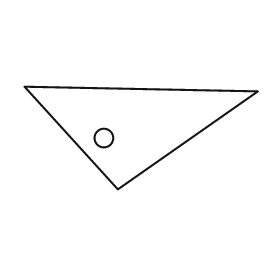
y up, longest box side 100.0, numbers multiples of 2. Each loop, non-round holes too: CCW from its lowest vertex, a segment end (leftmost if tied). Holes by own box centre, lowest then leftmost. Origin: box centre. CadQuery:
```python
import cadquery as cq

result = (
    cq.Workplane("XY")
    .moveTo(-10.0, -22.0)
    .lineTo(50.0, 20.0)
    .lineTo(-50.0, 22.0)
    .close()
    .moveTo(-16.0, 0.0)
    .circle(4.0)
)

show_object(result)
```